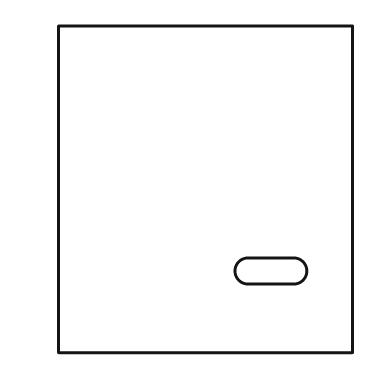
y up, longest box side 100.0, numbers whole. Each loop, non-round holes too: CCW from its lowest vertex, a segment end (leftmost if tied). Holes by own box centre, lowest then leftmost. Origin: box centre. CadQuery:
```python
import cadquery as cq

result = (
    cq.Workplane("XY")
    .moveTo(-45.0, -50.0)
    .lineTo(45.0, -50.0)
    .lineTo(45.0, 50.0)
    .lineTo(-45.0, 50.0)
    .close()
    .moveTo(13.0, -29.0)
    .lineTo(27.0, -29.0)
    .threePointArc((31.0, -25.0), (27.0, -21.0))
    .lineTo(13.0, -21.0)
    .threePointArc((9.0, -25.0), (13.0, -29.0))
    .close()
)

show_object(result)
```